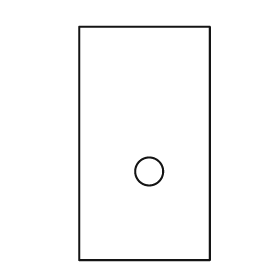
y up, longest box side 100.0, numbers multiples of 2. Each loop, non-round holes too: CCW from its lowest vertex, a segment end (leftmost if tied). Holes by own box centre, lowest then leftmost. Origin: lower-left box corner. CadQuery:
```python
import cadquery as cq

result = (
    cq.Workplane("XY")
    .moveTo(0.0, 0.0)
    .lineTo(56.0, 0.0)
    .lineTo(56.0, 100.0)
    .lineTo(0.0, 100.0)
    .close()
    .moveTo(30.0, 38.0)
    .circle(6.0)
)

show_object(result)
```